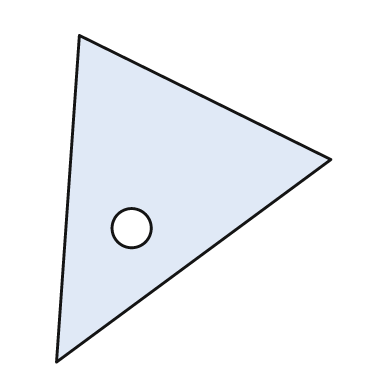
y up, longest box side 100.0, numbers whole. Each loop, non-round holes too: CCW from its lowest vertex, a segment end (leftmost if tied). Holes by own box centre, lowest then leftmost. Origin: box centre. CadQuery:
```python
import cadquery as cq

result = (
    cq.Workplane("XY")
    .moveTo(-42.0, -50.0)
    .lineTo(42.0, 12.0)
    .lineTo(-35.0, 50.0)
    .close()
    .moveTo(-19.0, -9.0)
    .circle(6.0)
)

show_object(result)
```